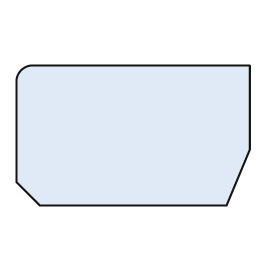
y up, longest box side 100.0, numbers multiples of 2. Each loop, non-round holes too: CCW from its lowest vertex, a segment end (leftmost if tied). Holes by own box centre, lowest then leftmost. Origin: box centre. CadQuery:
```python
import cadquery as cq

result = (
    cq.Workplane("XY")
    .moveTo(-40.0, -30.0)
    .lineTo(40.0, -30.0)
    .lineTo(50.0, -6.0)
    .lineTo(50.0, 30.0)
    .lineTo(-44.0, 30.0)
    .threePointArc((-48.0, 28.0), (-50.0, 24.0))
    .lineTo(-50.0, -20.0)
    .close()
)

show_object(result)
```